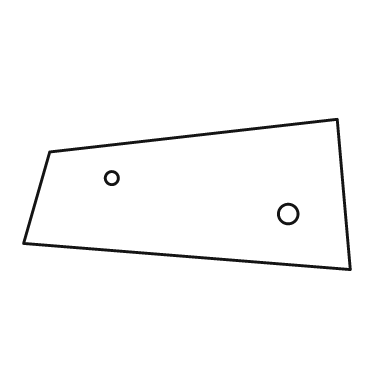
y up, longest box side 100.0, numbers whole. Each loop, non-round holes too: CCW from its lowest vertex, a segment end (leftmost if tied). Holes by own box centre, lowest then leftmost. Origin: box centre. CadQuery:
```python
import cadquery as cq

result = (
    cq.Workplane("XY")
    .moveTo(50.0, -23.0)
    .lineTo(46.0, 23.0)
    .lineTo(-42.0, 13.0)
    .lineTo(-50.0, -15.0)
    .close()
    .moveTo(31.0, -6.0)
    .circle(3.0)
    .moveTo(-23.0, 5.0)
    .circle(2.0)
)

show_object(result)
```